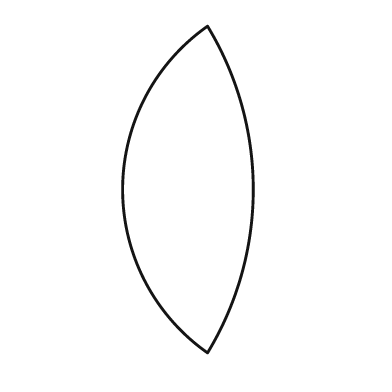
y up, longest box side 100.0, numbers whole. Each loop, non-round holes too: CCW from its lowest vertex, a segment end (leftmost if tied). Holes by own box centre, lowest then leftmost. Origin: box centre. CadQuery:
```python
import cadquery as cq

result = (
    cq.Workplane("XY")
    .moveTo(6.0, -50.0)
    .threePointArc((20.0, 0.0), (6.0, 50.0))
    .threePointArc((-20.0, 0.0), (6.0, -50.0))
    .close()
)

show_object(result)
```